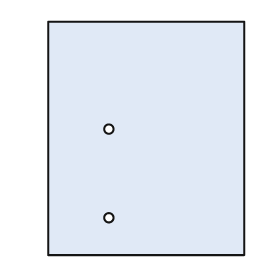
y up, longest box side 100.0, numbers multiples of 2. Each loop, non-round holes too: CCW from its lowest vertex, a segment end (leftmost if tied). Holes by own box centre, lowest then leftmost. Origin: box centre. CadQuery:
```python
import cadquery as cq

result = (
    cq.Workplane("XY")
    .moveTo(-42.0, -50.0)
    .lineTo(42.0, -50.0)
    .lineTo(42.0, 50.0)
    .lineTo(-42.0, 50.0)
    .close()
    .moveTo(-16.0, -34.0)
    .circle(2.0)
    .moveTo(-16.0, 4.0)
    .circle(2.0)
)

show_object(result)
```